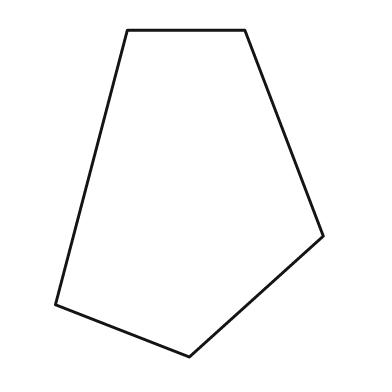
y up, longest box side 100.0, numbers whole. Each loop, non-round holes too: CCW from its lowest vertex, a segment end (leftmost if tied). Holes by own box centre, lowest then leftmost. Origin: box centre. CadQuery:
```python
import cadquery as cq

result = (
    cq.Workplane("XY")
    .moveTo(0.0, -50.0)
    .lineTo(41.0, -13.0)
    .lineTo(17.0, 50.0)
    .lineTo(-19.0, 50.0)
    .lineTo(-41.0, -34.0)
    .close()
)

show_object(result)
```